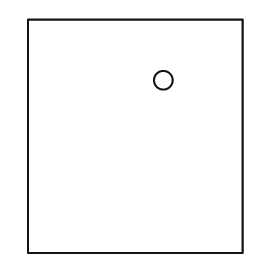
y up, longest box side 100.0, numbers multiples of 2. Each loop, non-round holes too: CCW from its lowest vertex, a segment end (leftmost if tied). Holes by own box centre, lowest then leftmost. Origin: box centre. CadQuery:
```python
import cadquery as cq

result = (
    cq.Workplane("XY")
    .moveTo(-46.0, -50.0)
    .lineTo(46.0, -50.0)
    .lineTo(46.0, 50.0)
    .lineTo(-46.0, 50.0)
    .close()
    .moveTo(12.0, 24.0)
    .circle(4.0)
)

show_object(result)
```